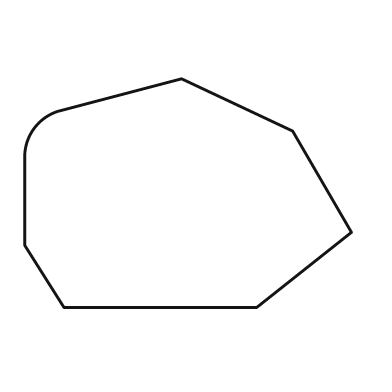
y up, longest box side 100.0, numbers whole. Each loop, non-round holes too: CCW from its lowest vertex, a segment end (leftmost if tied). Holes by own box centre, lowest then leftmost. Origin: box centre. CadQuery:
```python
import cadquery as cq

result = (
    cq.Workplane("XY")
    .moveTo(-38.0, -35.0)
    .lineTo(21.0, -35.0)
    .lineTo(50.0, -12.0)
    .lineTo(32.0, 19.0)
    .lineTo(-2.0, 35.0)
    .lineTo(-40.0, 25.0)
    .threePointArc((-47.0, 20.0), (-50.0, 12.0))
    .lineTo(-50.0, -16.0)
    .close()
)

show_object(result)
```